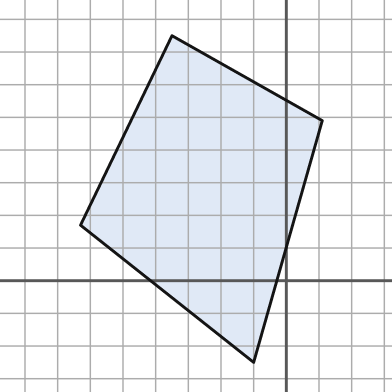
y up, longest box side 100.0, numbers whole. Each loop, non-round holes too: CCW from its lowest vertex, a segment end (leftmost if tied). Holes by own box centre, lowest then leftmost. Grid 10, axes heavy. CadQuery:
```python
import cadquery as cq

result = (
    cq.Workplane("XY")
    .moveTo(-10.0, -25.0)
    .lineTo(11.0, 49.0)
    .lineTo(-35.0, 75.0)
    .lineTo(-63.0, 17.0)
    .close()
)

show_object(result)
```